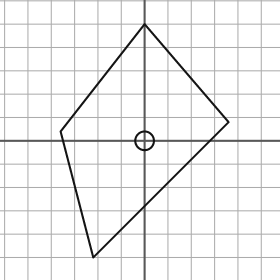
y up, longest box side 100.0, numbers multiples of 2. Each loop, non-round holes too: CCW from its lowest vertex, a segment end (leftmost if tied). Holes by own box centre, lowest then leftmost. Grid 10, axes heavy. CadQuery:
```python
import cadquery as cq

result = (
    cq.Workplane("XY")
    .moveTo(-22.0, -50.0)
    .lineTo(36.0, 8.0)
    .lineTo(0.0, 50.0)
    .lineTo(-36.0, 4.0)
    .close()
    .moveTo(0.0, 0.0)
    .circle(4.0)
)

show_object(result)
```